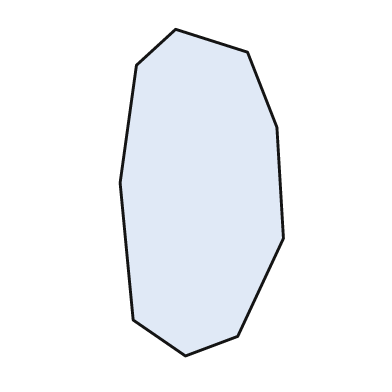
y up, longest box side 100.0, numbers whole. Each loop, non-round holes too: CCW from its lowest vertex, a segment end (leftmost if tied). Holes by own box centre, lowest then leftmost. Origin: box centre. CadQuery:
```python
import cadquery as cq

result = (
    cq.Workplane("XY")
    .moveTo(-5.0, -50.0)
    .lineTo(11.0, -44.0)
    .lineTo(25.0, -14.0)
    .lineTo(23.0, 20.0)
    .lineTo(14.0, 43.0)
    .lineTo(-8.0, 50.0)
    .lineTo(-20.0, 39.0)
    .lineTo(-25.0, 3.0)
    .lineTo(-21.0, -39.0)
    .close()
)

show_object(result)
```